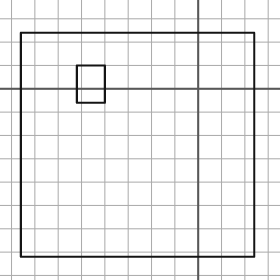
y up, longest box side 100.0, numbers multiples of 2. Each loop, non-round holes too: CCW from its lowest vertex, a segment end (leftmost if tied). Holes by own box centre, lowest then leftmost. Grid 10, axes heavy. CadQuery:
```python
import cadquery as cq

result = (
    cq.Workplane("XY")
    .moveTo(-76.0, -72.0)
    .lineTo(24.0, -72.0)
    .lineTo(24.0, 24.0)
    .lineTo(-76.0, 24.0)
    .close()
    .moveTo(-52.0, -6.0)
    .lineTo(-40.0, -6.0)
    .lineTo(-40.0, 10.0)
    .lineTo(-52.0, 10.0)
    .close()
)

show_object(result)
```